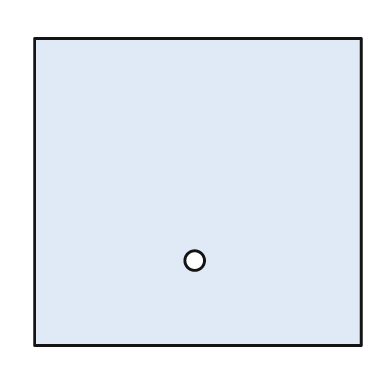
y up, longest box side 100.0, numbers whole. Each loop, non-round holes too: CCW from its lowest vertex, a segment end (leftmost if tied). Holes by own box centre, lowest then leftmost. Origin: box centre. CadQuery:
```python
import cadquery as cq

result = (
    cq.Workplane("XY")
    .moveTo(-50.0, -47.0)
    .lineTo(50.0, -47.0)
    .lineTo(50.0, 47.0)
    .lineTo(-50.0, 47.0)
    .close()
    .moveTo(-1.0, -21.0)
    .circle(3.0)
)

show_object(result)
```